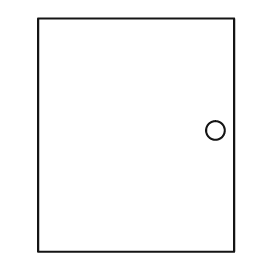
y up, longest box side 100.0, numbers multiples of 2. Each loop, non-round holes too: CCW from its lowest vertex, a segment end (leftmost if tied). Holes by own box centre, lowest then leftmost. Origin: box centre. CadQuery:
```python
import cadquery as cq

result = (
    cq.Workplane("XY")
    .moveTo(-42.0, -50.0)
    .lineTo(42.0, -50.0)
    .lineTo(42.0, 50.0)
    .lineTo(-42.0, 50.0)
    .close()
    .moveTo(34.0, 2.0)
    .circle(4.0)
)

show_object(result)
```